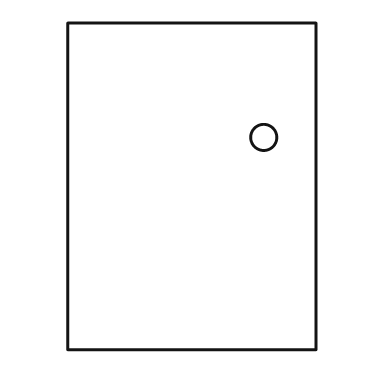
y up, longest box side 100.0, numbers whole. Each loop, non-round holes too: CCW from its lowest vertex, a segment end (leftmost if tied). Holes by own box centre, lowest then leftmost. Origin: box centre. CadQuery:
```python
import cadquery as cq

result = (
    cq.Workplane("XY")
    .moveTo(-38.0, -50.0)
    .lineTo(38.0, -50.0)
    .lineTo(38.0, 50.0)
    .lineTo(-38.0, 50.0)
    .close()
    .moveTo(22.0, 15.0)
    .circle(4.0)
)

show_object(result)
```